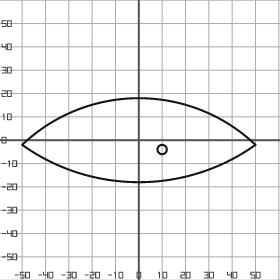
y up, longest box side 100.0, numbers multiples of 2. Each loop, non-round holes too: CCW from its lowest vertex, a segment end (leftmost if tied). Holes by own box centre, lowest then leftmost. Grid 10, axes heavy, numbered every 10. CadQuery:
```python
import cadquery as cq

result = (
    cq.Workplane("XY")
    .moveTo(-50.0, -2.0)
    .threePointArc((0.0, -18.0), (50.0, -2.0))
    .threePointArc((0.0, 18.0), (-50.0, -2.0))
    .close()
    .moveTo(10.0, -4.0)
    .circle(2.0)
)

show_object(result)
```